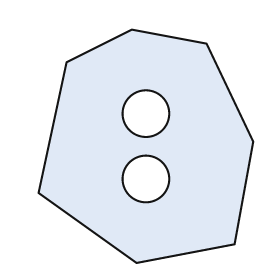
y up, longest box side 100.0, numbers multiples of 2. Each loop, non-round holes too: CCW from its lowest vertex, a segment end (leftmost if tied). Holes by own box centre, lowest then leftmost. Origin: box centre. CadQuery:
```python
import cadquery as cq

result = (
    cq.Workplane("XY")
    .moveTo(-4.0, -50.0)
    .lineTo(38.0, -42.0)
    .lineTo(46.0, 2.0)
    .lineTo(26.0, 44.0)
    .lineTo(-6.0, 50.0)
    .lineTo(-34.0, 36.0)
    .lineTo(-46.0, -20.0)
    .close()
    .moveTo(0.0, -14.0)
    .circle(10.0)
    .moveTo(0.0, 14.0)
    .circle(10.0)
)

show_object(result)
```